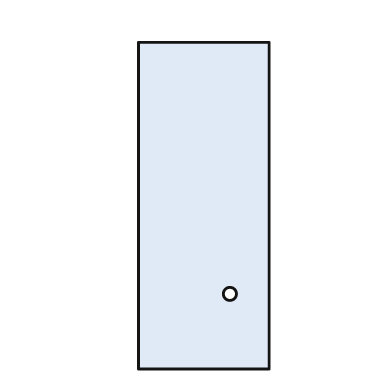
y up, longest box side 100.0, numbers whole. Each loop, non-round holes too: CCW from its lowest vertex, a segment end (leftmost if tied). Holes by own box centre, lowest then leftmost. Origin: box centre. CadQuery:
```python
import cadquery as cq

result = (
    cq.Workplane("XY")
    .moveTo(-20.0, -50.0)
    .lineTo(20.0, -50.0)
    .lineTo(20.0, 50.0)
    .lineTo(-20.0, 50.0)
    .close()
    .moveTo(8.0, -27.0)
    .circle(2.0)
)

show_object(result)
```